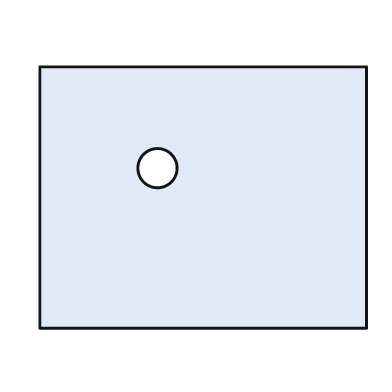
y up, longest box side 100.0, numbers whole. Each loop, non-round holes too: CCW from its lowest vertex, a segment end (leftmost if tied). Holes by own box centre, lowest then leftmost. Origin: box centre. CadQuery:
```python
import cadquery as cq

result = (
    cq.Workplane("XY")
    .moveTo(-50.0, -40.0)
    .lineTo(50.0, -40.0)
    .lineTo(50.0, 40.0)
    .lineTo(-50.0, 40.0)
    .close()
    .moveTo(-14.0, 9.0)
    .circle(6.0)
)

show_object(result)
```